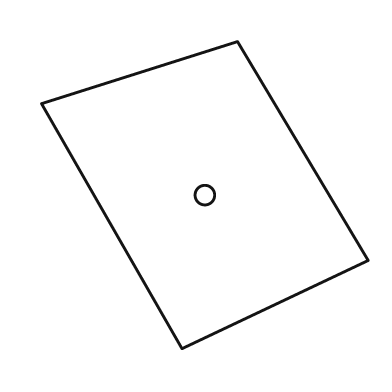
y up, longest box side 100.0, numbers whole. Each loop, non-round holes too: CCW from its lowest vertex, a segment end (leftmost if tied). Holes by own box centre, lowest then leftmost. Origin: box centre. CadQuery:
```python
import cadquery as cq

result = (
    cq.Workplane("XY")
    .moveTo(-7.0, -47.0)
    .lineTo(50.0, -20.0)
    .lineTo(10.0, 47.0)
    .lineTo(-50.0, 28.0)
    .close()
    .moveTo(0.0, 0.0)
    .circle(3.0)
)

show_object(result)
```